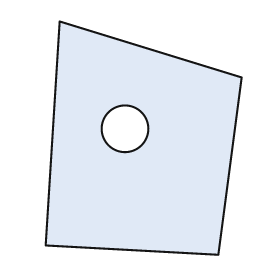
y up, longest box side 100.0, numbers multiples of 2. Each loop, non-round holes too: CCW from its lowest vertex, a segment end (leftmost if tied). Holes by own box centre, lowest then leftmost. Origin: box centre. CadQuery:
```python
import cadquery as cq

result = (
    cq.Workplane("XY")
    .moveTo(32.0, -50.0)
    .lineTo(42.0, 26.0)
    .lineTo(-36.0, 50.0)
    .lineTo(-42.0, -46.0)
    .close()
    .moveTo(-8.0, 4.0)
    .circle(10.0)
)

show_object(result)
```